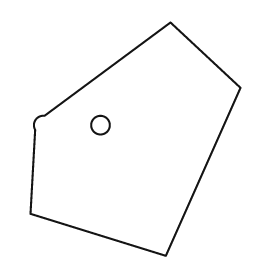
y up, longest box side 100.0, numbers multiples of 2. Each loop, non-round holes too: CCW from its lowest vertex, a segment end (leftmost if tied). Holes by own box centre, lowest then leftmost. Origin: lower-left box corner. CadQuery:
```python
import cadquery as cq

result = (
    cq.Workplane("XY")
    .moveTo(58.0, 0.0)
    .lineTo(90.0, 72.0)
    .lineTo(60.0, 100.0)
    .lineTo(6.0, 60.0)
    .threePointArc((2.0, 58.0), (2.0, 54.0))
    .lineTo(0.0, 18.0)
    .close()
    .moveTo(30.0, 56.0)
    .circle(4.0)
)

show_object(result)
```